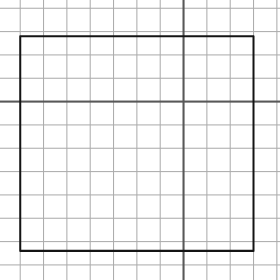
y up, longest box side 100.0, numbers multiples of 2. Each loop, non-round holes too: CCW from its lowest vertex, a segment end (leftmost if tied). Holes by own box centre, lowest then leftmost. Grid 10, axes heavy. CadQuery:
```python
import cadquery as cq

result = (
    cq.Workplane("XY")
    .moveTo(-70.0, -64.0)
    .lineTo(30.0, -64.0)
    .lineTo(30.0, 28.0)
    .lineTo(-70.0, 28.0)
    .close()
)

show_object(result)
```